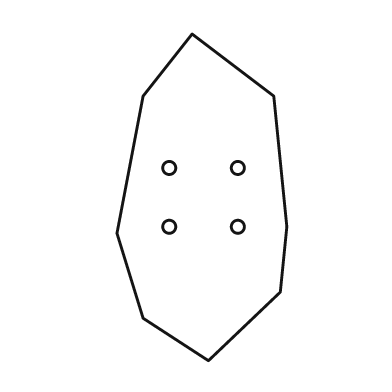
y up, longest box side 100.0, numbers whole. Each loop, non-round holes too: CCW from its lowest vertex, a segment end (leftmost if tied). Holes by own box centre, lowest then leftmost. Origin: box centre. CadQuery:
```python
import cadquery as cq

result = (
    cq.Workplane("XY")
    .moveTo(2.0, -50.0)
    .lineTo(24.0, -29.0)
    .lineTo(26.0, -9.0)
    .lineTo(22.0, 31.0)
    .lineTo(-3.0, 50.0)
    .lineTo(-18.0, 31.0)
    .lineTo(-26.0, -11.0)
    .lineTo(-18.0, -37.0)
    .close()
    .moveTo(-10.0, -9.0)
    .circle(2.0)
    .moveTo(11.0, -9.0)
    .circle(2.0)
    .moveTo(-10.0, 9.0)
    .circle(2.0)
    .moveTo(11.0, 9.0)
    .circle(2.0)
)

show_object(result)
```